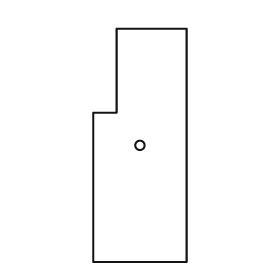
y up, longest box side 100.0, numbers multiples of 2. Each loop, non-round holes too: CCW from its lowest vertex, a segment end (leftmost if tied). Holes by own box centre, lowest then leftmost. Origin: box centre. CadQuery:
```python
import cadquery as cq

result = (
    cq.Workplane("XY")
    .moveTo(-20.0, -50.0)
    .lineTo(20.0, -50.0)
    .lineTo(20.0, 50.0)
    .lineTo(-10.0, 50.0)
    .lineTo(-10.0, 14.0)
    .lineTo(-20.0, 14.0)
    .close()
    .moveTo(0.0, 0.0)
    .circle(2.0)
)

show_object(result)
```